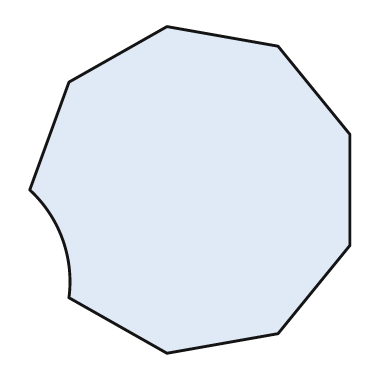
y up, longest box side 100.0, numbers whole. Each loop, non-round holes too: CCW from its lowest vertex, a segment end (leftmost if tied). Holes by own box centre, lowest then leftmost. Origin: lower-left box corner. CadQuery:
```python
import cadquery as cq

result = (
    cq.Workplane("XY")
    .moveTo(42.0, 0.0)
    .lineTo(76.0, 6.0)
    .lineTo(98.0, 33.0)
    .lineTo(98.0, 67.0)
    .lineTo(76.0, 94.0)
    .lineTo(42.0, 100.0)
    .lineTo(12.0, 83.0)
    .lineTo(0.0, 50.0)
    .threePointArc((10.0, 35.0), (12.0, 17.0))
    .close()
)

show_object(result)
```